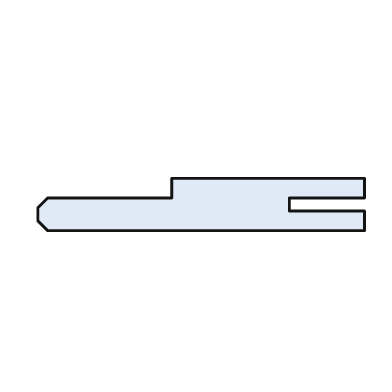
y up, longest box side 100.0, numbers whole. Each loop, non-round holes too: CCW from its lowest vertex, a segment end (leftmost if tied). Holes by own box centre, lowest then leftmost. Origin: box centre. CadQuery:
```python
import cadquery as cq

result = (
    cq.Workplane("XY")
    .moveTo(-47.0, -8.0)
    .lineTo(50.0, -8.0)
    .lineTo(50.0, -2.0)
    .lineTo(27.0, -2.0)
    .lineTo(27.0, 2.0)
    .lineTo(50.0, 2.0)
    .lineTo(50.0, 8.0)
    .lineTo(-9.0, 8.0)
    .lineTo(-9.0, 2.0)
    .lineTo(-47.0, 2.0)
    .lineTo(-50.0, -1.0)
    .lineTo(-50.0, -5.0)
    .close()
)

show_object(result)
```